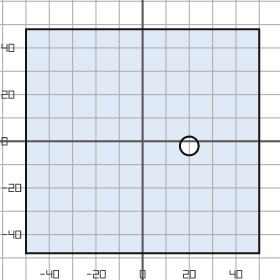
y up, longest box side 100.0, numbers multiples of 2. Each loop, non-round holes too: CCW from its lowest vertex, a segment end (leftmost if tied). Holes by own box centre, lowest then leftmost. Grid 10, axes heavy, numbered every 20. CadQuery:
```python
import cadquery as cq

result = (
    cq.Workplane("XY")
    .moveTo(-50.0, -48.0)
    .lineTo(50.0, -48.0)
    .lineTo(50.0, 48.0)
    .lineTo(-50.0, 48.0)
    .close()
    .moveTo(20.0, -2.0)
    .circle(4.0)
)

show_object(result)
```